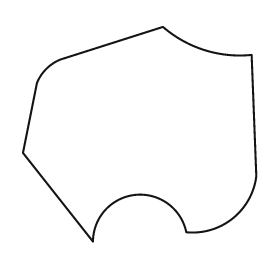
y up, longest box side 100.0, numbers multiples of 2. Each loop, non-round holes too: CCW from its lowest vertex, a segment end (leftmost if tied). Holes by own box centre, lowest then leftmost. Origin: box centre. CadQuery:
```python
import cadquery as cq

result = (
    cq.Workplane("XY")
    .moveTo(-20.0, -46.0)
    .threePointArc((-2.0, -26.0), (20.0, -42.0))
    .threePointArc((40.0, -36.0), (50.0, -18.0))
    .lineTo(48.0, 34.0)
    .threePointArc((28.0, 36.0), (10.0, 46.0))
    .lineTo(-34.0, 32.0)
    .threePointArc((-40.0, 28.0), (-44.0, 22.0))
    .lineTo(-50.0, -8.0)
    .close()
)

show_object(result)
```